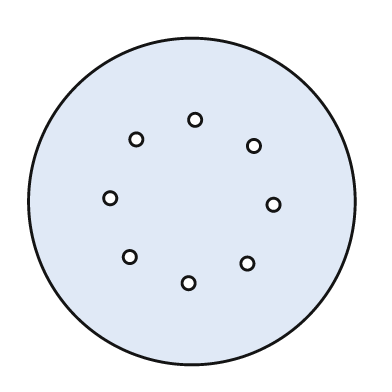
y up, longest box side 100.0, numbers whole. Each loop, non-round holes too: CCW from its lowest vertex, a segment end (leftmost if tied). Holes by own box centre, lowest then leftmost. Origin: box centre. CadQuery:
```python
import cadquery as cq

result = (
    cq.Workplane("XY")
    .moveTo(0.0, 0.0)
    .circle(50.0)
    .moveTo(-1.0, -25.0)
    .circle(2.0)
    .moveTo(17.0, -19.0)
    .circle(2.0)
    .moveTo(-19.0, -17.0)
    .circle(2.0)
    .moveTo(25.0, -1.0)
    .circle(2.0)
    .moveTo(-25.0, 1.0)
    .circle(2.0)
    .moveTo(19.0, 17.0)
    .circle(2.0)
    .moveTo(-17.0, 19.0)
    .circle(2.0)
    .moveTo(1.0, 25.0)
    .circle(2.0)
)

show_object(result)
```